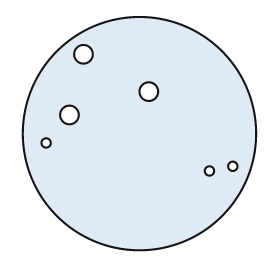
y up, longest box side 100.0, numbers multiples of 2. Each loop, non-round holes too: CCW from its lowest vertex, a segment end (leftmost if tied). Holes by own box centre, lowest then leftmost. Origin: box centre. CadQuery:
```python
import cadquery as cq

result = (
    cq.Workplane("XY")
    .moveTo(0.0, 0.0)
    .circle(50.0)
    .moveTo(30.0, -16.0)
    .circle(2.0)
    .moveTo(40.0, -14.0)
    .circle(2.0)
    .moveTo(-40.0, -4.0)
    .circle(2.0)
    .moveTo(-30.0, 8.0)
    .circle(4.0)
    .moveTo(4.0, 18.0)
    .circle(4.0)
    .moveTo(-24.0, 34.0)
    .circle(4.0)
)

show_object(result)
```